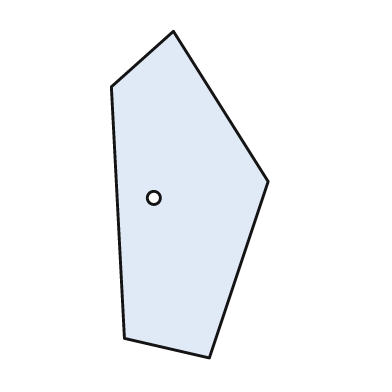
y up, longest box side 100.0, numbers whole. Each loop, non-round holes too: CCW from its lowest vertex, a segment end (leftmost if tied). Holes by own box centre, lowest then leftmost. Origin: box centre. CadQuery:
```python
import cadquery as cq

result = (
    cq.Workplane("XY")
    .moveTo(6.0, -50.0)
    .lineTo(24.0, 4.0)
    .lineTo(-5.0, 50.0)
    .lineTo(-24.0, 33.0)
    .lineTo(-20.0, -44.0)
    .close()
    .moveTo(-11.0, -1.0)
    .circle(2.0)
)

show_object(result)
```